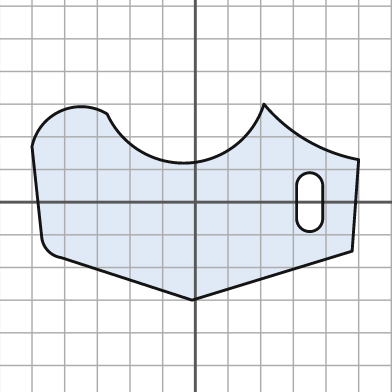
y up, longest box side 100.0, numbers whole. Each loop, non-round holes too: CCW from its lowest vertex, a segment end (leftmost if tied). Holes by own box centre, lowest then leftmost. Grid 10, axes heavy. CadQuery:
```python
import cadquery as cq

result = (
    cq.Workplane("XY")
    .moveTo(-1.0, -30.0)
    .lineTo(48.0, -15.0)
    .lineTo(50.0, 13.0)
    .threePointArc((34.0, 19.0), (21.0, 30.0))
    .threePointArc((-2.0, 12.0), (-27.0, 27.0))
    .threePointArc((-41.0, 28.0), (-50.0, 17.0))
    .lineTo(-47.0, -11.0)
    .threePointArc((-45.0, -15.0), (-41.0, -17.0))
    .close()
    .moveTo(31.0, -5.0)
    .threePointArc((35.0, -9.0), (39.0, -5.0))
    .lineTo(39.0, 5.0)
    .threePointArc((35.0, 9.0), (31.0, 5.0))
    .close()
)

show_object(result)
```